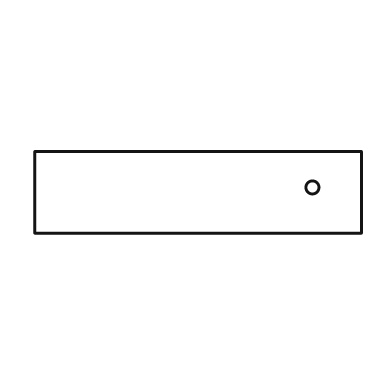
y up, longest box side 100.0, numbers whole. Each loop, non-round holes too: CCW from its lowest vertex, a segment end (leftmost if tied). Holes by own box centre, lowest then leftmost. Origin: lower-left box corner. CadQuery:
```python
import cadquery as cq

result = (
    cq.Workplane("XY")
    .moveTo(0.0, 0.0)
    .lineTo(100.0, 0.0)
    .lineTo(100.0, 25.0)
    .lineTo(0.0, 25.0)
    .close()
    .moveTo(85.0, 14.0)
    .circle(2.0)
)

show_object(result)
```